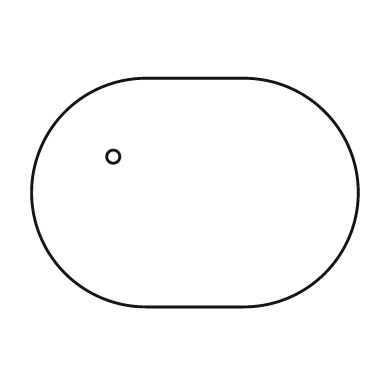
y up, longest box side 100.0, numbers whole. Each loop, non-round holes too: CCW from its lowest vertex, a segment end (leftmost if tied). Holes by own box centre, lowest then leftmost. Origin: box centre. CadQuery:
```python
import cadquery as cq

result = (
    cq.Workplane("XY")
    .moveTo(-15.0, -35.0)
    .lineTo(15.0, -35.0)
    .threePointArc((50.0, 0.0), (15.0, 35.0))
    .lineTo(-15.0, 35.0)
    .threePointArc((-50.0, 0.0), (-15.0, -35.0))
    .close()
    .moveTo(-25.0, 11.0)
    .circle(2.0)
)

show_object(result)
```